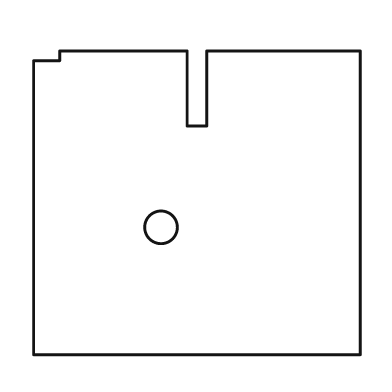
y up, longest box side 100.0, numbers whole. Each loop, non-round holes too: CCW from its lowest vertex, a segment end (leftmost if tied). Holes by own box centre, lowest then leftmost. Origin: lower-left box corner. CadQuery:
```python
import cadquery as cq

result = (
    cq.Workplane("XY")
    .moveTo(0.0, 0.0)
    .lineTo(100.0, 0.0)
    .lineTo(100.0, 93.0)
    .lineTo(53.0, 93.0)
    .lineTo(53.0, 70.0)
    .lineTo(47.0, 70.0)
    .lineTo(47.0, 93.0)
    .lineTo(8.0, 93.0)
    .lineTo(8.0, 90.0)
    .lineTo(0.0, 90.0)
    .close()
    .moveTo(39.0, 39.0)
    .circle(5.0)
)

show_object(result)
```